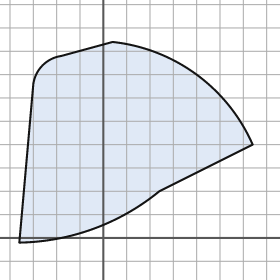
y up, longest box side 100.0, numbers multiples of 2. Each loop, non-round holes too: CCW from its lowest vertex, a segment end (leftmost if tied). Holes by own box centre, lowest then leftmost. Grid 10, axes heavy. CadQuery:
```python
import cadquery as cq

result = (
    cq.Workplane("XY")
    .moveTo(-36.0, -2.0)
    .threePointArc((-4.0, 4.0), (24.0, 20.0))
    .lineTo(64.0, 40.0)
    .threePointArc((40.0, 70.0), (4.0, 84.0))
    .lineTo(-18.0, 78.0)
    .threePointArc((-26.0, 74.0), (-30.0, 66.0))
    .close()
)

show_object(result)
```